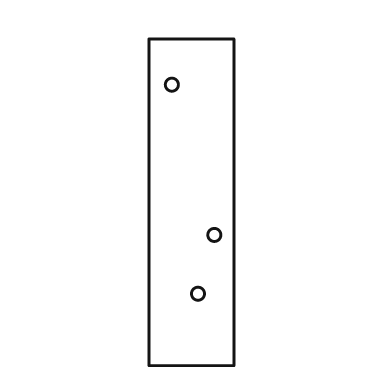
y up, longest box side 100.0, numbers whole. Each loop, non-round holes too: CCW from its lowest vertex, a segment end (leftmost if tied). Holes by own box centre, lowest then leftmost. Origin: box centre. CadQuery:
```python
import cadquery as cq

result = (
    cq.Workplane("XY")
    .moveTo(-13.0, -50.0)
    .lineTo(13.0, -50.0)
    .lineTo(13.0, 50.0)
    .lineTo(-13.0, 50.0)
    .close()
    .moveTo(2.0, -28.0)
    .circle(2.0)
    .moveTo(7.0, -10.0)
    .circle(2.0)
    .moveTo(-6.0, 36.0)
    .circle(2.0)
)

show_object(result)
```